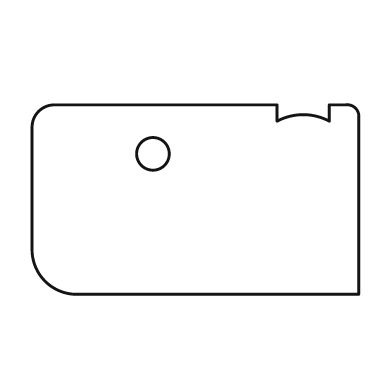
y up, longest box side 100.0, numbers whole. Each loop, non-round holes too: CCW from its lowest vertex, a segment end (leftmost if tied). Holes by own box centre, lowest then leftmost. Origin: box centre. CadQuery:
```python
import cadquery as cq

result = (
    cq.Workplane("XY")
    .moveTo(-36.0, -29.0)
    .lineTo(50.0, -29.0)
    .lineTo(50.0, 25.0)
    .threePointArc((49.0, 28.0), (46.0, 29.0))
    .lineTo(41.0, 29.0)
    .lineTo(41.0, 24.0)
    .threePointArc((33.0, 26.0), (25.0, 24.0))
    .lineTo(25.0, 29.0)
    .lineTo(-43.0, 29.0)
    .threePointArc((-48.0, 27.0), (-50.0, 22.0))
    .lineTo(-50.0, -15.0)
    .threePointArc((-46.0, -25.0), (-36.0, -29.0))
    .close()
    .moveTo(-13.0, 14.0)
    .circle(5.0)
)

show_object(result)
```